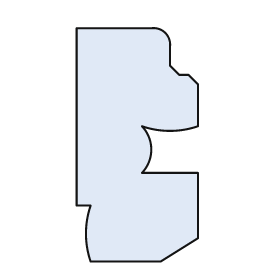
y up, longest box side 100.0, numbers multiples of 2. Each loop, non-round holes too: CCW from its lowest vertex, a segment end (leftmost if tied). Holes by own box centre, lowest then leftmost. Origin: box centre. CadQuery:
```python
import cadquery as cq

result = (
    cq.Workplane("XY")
    .moveTo(-20.0, -50.0)
    .lineTo(10.0, -50.0)
    .lineTo(26.0, -40.0)
    .lineTo(26.0, -12.0)
    .lineTo(2.0, -12.0)
    .threePointArc((6.0, -2.0), (2.0, 8.0))
    .threePointArc((14.0, 6.0), (26.0, 8.0))
    .lineTo(26.0, 26.0)
    .lineTo(22.0, 30.0)
    .lineTo(18.0, 30.0)
    .lineTo(14.0, 34.0)
    .lineTo(14.0, 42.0)
    .threePointArc((12.0, 48.0), (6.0, 50.0))
    .lineTo(-26.0, 50.0)
    .lineTo(-26.0, -26.0)
    .lineTo(-20.0, -26.0)
    .threePointArc((-22.0, -38.0), (-20.0, -50.0))
    .close()
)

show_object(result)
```